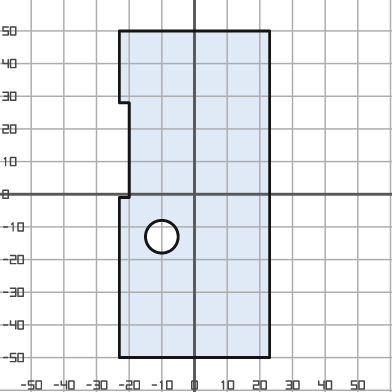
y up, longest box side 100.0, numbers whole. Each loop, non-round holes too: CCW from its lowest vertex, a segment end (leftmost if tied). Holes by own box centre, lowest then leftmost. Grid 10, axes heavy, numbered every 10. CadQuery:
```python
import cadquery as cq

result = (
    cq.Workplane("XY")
    .moveTo(-23.0, -50.0)
    .lineTo(23.0, -50.0)
    .lineTo(23.0, 50.0)
    .lineTo(-23.0, 50.0)
    .lineTo(-23.0, 28.0)
    .lineTo(-20.0, 28.0)
    .lineTo(-20.0, -1.0)
    .lineTo(-23.0, -1.0)
    .close()
    .moveTo(-10.0, -13.0)
    .circle(5.0)
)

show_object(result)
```